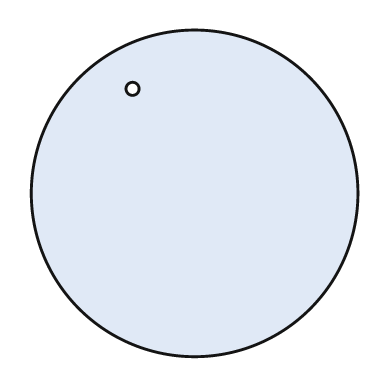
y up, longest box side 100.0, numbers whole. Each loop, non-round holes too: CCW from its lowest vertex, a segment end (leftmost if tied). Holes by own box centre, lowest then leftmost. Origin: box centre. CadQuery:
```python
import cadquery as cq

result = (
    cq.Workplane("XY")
    .moveTo(0.0, 0.0)
    .circle(50.0)
    .moveTo(-19.0, 32.0)
    .circle(2.0)
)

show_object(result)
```